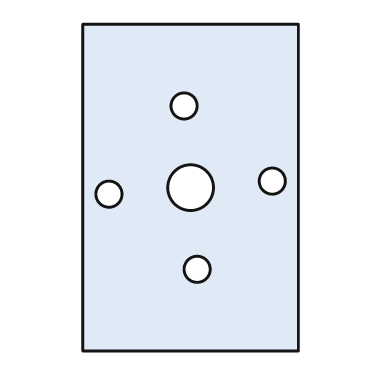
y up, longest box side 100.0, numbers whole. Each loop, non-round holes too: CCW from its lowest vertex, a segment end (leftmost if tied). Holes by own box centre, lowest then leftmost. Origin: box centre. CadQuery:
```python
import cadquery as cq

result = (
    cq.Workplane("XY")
    .moveTo(-33.0, -50.0)
    .lineTo(33.0, -50.0)
    .lineTo(33.0, 50.0)
    .lineTo(-33.0, 50.0)
    .close()
    .moveTo(2.0, -25.0)
    .circle(4.0)
    .moveTo(-25.0, -2.0)
    .circle(4.0)
    .moveTo(0.0, 0.0)
    .circle(7.0)
    .moveTo(25.0, 2.0)
    .circle(4.0)
    .moveTo(-2.0, 25.0)
    .circle(4.0)
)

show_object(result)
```